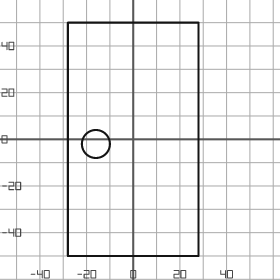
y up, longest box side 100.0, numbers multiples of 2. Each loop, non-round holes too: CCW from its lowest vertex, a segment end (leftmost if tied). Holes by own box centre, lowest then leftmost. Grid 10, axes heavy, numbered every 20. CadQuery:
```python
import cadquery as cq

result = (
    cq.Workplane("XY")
    .moveTo(-28.0, -50.0)
    .lineTo(28.0, -50.0)
    .lineTo(28.0, 50.0)
    .lineTo(-28.0, 50.0)
    .close()
    .moveTo(-16.0, -2.0)
    .circle(6.0)
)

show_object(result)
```